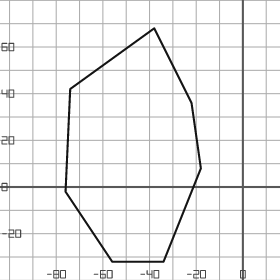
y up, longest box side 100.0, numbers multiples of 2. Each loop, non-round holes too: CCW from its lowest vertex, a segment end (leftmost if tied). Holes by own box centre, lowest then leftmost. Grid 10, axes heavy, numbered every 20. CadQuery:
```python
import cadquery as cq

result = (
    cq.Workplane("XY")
    .moveTo(-56.0, -32.0)
    .lineTo(-34.0, -32.0)
    .lineTo(-18.0, 8.0)
    .lineTo(-22.0, 36.0)
    .lineTo(-38.0, 68.0)
    .lineTo(-74.0, 42.0)
    .lineTo(-76.0, -2.0)
    .close()
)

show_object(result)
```